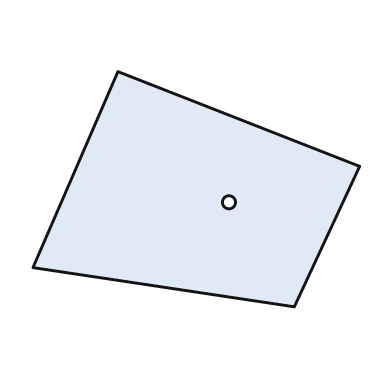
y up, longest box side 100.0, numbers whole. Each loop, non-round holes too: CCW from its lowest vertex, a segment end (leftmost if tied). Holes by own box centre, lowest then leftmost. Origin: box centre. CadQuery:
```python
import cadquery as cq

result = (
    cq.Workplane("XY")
    .moveTo(30.0, -36.0)
    .lineTo(50.0, 7.0)
    .lineTo(-24.0, 36.0)
    .lineTo(-50.0, -24.0)
    .close()
    .moveTo(10.0, -4.0)
    .circle(2.0)
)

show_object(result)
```